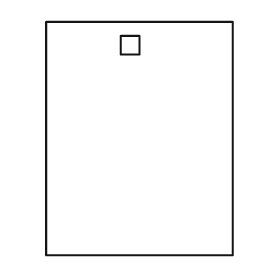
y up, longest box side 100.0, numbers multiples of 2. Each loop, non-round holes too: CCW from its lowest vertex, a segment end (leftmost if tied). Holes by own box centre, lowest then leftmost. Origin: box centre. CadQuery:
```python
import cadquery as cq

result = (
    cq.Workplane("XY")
    .moveTo(-40.0, -50.0)
    .lineTo(40.0, -50.0)
    .lineTo(40.0, 50.0)
    .lineTo(-40.0, 50.0)
    .close()
    .moveTo(-8.0, 36.0)
    .lineTo(0.0, 36.0)
    .lineTo(0.0, 44.0)
    .lineTo(-8.0, 44.0)
    .close()
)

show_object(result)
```